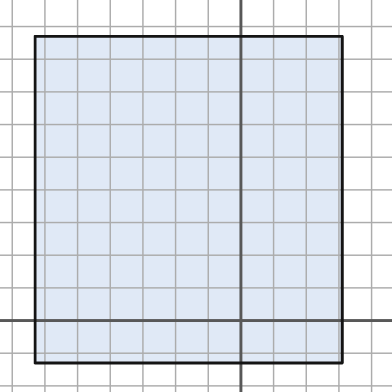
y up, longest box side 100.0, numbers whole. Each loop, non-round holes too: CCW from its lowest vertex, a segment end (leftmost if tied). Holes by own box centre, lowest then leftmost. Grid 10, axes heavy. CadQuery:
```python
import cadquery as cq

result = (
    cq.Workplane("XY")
    .moveTo(-63.0, -13.0)
    .lineTo(31.0, -13.0)
    .lineTo(31.0, 87.0)
    .lineTo(-63.0, 87.0)
    .close()
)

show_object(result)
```